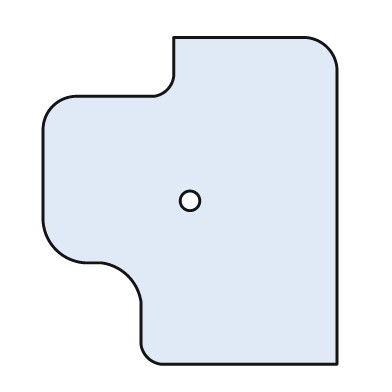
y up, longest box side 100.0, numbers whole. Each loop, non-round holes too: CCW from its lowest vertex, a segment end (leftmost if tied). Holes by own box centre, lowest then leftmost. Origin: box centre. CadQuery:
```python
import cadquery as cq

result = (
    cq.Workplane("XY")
    .moveTo(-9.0, -50.0)
    .lineTo(45.0, -50.0)
    .lineTo(45.0, 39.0)
    .threePointArc((42.0, 47.0), (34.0, 50.0))
    .lineTo(-5.0, 50.0)
    .lineTo(-5.0, 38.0)
    .threePointArc((-7.0, 34.0), (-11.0, 32.0))
    .lineTo(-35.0, 32.0)
    .threePointArc((-42.0, 29.0), (-45.0, 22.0))
    .lineTo(-45.0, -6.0)
    .threePointArc((-41.0, -15.0), (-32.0, -19.0))
    .lineTo(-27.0, -19.0)
    .threePointArc((-19.0, -23.0), (-15.0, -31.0))
    .lineTo(-15.0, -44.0)
    .threePointArc((-13.0, -48.0), (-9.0, -50.0))
    .close()
    .moveTo(0.0, 0.0)
    .circle(3.0)
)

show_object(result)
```